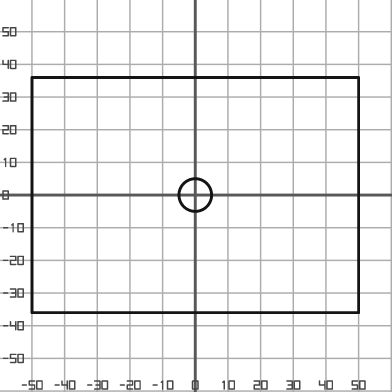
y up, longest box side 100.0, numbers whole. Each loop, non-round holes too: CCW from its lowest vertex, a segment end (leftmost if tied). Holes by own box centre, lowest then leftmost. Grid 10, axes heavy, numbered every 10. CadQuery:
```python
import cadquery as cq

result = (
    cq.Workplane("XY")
    .moveTo(-50.0, -36.0)
    .lineTo(50.0, -36.0)
    .lineTo(50.0, 36.0)
    .lineTo(-50.0, 36.0)
    .close()
    .moveTo(0.0, 0.0)
    .circle(5.0)
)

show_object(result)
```